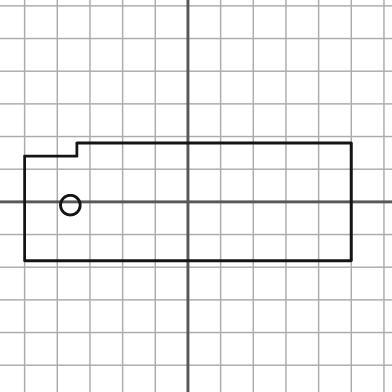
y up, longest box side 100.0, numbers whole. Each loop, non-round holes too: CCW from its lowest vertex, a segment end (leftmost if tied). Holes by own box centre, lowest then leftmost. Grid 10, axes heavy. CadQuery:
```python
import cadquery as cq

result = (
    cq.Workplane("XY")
    .moveTo(-50.0, -18.0)
    .lineTo(50.0, -18.0)
    .lineTo(50.0, 18.0)
    .lineTo(-34.0, 18.0)
    .lineTo(-34.0, 14.0)
    .lineTo(-50.0, 14.0)
    .close()
    .moveTo(-36.0, -1.0)
    .circle(3.0)
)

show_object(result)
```